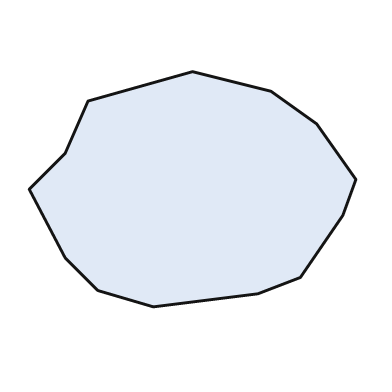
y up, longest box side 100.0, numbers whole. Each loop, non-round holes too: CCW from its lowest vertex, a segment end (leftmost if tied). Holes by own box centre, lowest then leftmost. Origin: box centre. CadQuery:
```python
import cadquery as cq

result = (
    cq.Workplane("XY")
    .moveTo(-12.0, -36.0)
    .lineTo(20.0, -32.0)
    .lineTo(33.0, -27.0)
    .lineTo(46.0, -8.0)
    .lineTo(50.0, 3.0)
    .lineTo(38.0, 20.0)
    .lineTo(24.0, 30.0)
    .lineTo(0.0, 36.0)
    .lineTo(-32.0, 27.0)
    .lineTo(-39.0, 11.0)
    .lineTo(-50.0, 0.0)
    .lineTo(-39.0, -21.0)
    .lineTo(-29.0, -31.0)
    .close()
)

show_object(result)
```